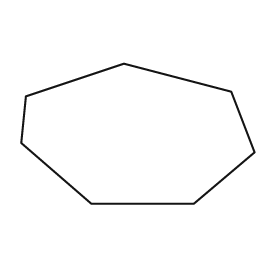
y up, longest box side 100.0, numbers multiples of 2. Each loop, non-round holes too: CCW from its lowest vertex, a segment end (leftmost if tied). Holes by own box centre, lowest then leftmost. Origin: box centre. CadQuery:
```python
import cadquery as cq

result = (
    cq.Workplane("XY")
    .moveTo(-20.0, -30.0)
    .lineTo(24.0, -30.0)
    .lineTo(50.0, -8.0)
    .lineTo(40.0, 18.0)
    .lineTo(-6.0, 30.0)
    .lineTo(-48.0, 16.0)
    .lineTo(-50.0, -4.0)
    .close()
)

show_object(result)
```